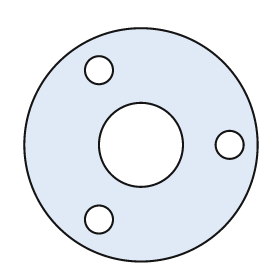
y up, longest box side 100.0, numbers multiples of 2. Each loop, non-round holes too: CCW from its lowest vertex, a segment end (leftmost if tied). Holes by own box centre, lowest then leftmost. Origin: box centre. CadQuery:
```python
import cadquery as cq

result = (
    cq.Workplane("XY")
    .moveTo(0.0, 0.0)
    .circle(50.0)
    .moveTo(-18.0, -32.0)
    .circle(6.0)
    .moveTo(0.0, 0.0)
    .circle(18.0)
    .moveTo(38.0, 0.0)
    .circle(6.0)
    .moveTo(-18.0, 32.0)
    .circle(6.0)
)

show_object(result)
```